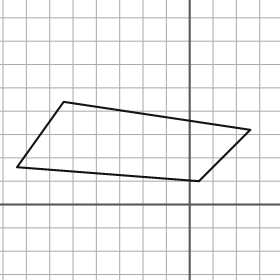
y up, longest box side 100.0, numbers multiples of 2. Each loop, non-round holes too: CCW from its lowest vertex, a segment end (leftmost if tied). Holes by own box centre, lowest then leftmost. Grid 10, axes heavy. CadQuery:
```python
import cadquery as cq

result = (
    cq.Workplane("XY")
    .moveTo(4.0, 10.0)
    .lineTo(26.0, 32.0)
    .lineTo(-54.0, 44.0)
    .lineTo(-74.0, 16.0)
    .close()
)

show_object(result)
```